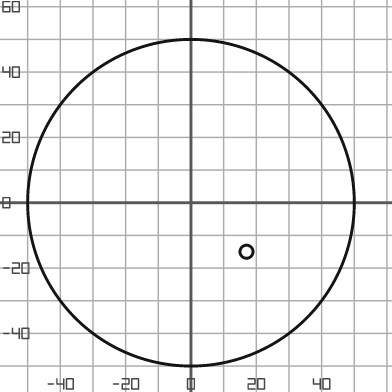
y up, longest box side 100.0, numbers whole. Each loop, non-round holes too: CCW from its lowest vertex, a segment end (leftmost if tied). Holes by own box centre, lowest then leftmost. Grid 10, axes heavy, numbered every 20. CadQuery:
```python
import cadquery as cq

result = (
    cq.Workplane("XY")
    .moveTo(0.0, 0.0)
    .circle(50.0)
    .moveTo(17.0, -15.0)
    .circle(2.0)
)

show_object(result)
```